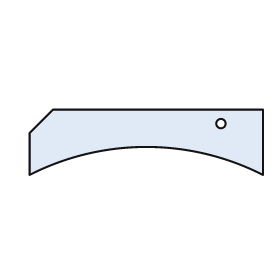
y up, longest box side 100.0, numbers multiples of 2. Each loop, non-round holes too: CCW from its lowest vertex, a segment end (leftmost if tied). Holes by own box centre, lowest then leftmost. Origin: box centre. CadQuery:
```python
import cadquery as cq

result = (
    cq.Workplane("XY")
    .moveTo(-50.0, -14.0)
    .threePointArc((0.0, -2.0), (50.0, -14.0))
    .lineTo(50.0, 14.0)
    .lineTo(-40.0, 14.0)
    .lineTo(-50.0, 4.0)
    .close()
    .moveTo(32.0, 8.0)
    .circle(2.0)
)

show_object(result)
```